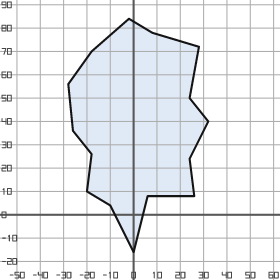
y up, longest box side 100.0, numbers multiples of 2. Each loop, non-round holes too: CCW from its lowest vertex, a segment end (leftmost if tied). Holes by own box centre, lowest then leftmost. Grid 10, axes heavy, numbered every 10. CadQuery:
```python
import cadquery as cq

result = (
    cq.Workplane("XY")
    .moveTo(0.0, -16.0)
    .lineTo(6.0, 8.0)
    .lineTo(26.0, 8.0)
    .lineTo(24.0, 24.0)
    .lineTo(32.0, 40.0)
    .lineTo(24.0, 50.0)
    .lineTo(28.0, 72.0)
    .lineTo(8.0, 78.0)
    .lineTo(-2.0, 84.0)
    .lineTo(-18.0, 70.0)
    .lineTo(-28.0, 56.0)
    .lineTo(-26.0, 36.0)
    .lineTo(-18.0, 26.0)
    .lineTo(-20.0, 10.0)
    .lineTo(-10.0, 4.0)
    .close()
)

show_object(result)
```